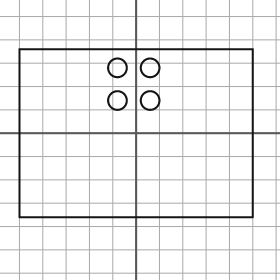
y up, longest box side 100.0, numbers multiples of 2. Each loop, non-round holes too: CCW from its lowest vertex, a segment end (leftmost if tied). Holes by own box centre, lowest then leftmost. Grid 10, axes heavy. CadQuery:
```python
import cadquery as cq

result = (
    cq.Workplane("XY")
    .moveTo(-50.0, -36.0)
    .lineTo(50.0, -36.0)
    .lineTo(50.0, 36.0)
    .lineTo(-50.0, 36.0)
    .close()
    .moveTo(-8.0, 14.0)
    .circle(4.0)
    .moveTo(6.0, 14.0)
    .circle(4.0)
    .moveTo(-8.0, 28.0)
    .circle(4.0)
    .moveTo(6.0, 28.0)
    .circle(4.0)
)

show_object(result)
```